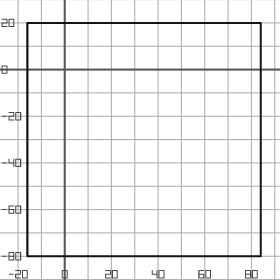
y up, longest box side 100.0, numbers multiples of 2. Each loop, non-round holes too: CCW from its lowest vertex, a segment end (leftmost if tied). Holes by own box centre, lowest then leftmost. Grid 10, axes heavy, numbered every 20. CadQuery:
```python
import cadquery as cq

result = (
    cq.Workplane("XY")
    .moveTo(-16.0, -80.0)
    .lineTo(84.0, -80.0)
    .lineTo(84.0, 20.0)
    .lineTo(-16.0, 20.0)
    .close()
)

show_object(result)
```